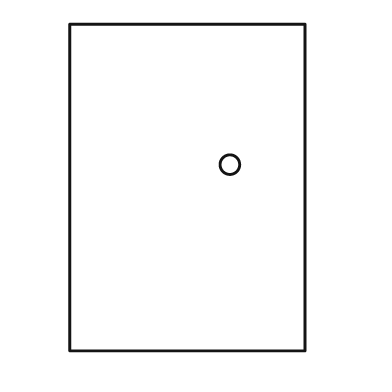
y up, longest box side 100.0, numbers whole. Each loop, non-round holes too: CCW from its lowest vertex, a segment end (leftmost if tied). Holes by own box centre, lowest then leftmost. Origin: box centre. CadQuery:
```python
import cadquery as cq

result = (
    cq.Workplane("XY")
    .moveTo(-36.0, -50.0)
    .lineTo(36.0, -50.0)
    .lineTo(36.0, 50.0)
    .lineTo(-36.0, 50.0)
    .close()
    .moveTo(13.0, 7.0)
    .circle(3.0)
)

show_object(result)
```